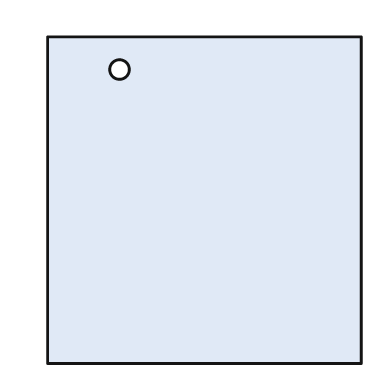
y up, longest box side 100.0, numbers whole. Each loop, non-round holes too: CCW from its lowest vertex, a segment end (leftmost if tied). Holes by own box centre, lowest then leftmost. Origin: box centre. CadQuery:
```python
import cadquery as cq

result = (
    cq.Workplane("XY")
    .moveTo(-48.0, -50.0)
    .lineTo(48.0, -50.0)
    .lineTo(48.0, 50.0)
    .lineTo(-48.0, 50.0)
    .close()
    .moveTo(-26.0, 40.0)
    .circle(3.0)
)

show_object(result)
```